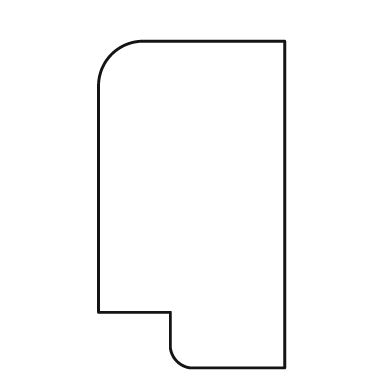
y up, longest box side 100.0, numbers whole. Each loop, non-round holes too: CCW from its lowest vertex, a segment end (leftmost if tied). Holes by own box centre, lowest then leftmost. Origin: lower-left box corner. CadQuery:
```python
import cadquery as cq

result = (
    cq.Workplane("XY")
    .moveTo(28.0, 0.0)
    .lineTo(57.0, 0.0)
    .lineTo(57.0, 100.0)
    .lineTo(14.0, 100.0)
    .threePointArc((4.0, 96.0), (0.0, 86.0))
    .lineTo(0.0, 17.0)
    .lineTo(22.0, 17.0)
    .lineTo(22.0, 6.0)
    .threePointArc((24.0, 2.0), (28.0, 0.0))
    .close()
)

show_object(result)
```